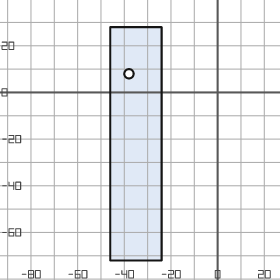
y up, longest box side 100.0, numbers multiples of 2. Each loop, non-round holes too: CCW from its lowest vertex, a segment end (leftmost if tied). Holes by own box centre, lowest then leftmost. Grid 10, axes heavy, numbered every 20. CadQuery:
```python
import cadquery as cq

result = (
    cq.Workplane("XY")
    .moveTo(-46.0, -72.0)
    .lineTo(-24.0, -72.0)
    .lineTo(-24.0, 28.0)
    .lineTo(-46.0, 28.0)
    .close()
    .moveTo(-38.0, 8.0)
    .circle(2.0)
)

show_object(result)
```